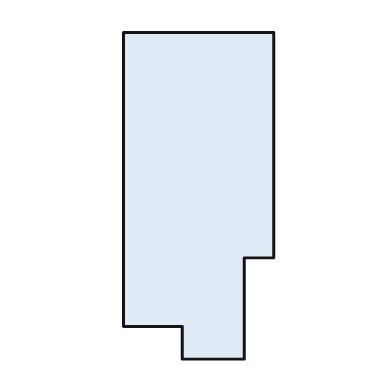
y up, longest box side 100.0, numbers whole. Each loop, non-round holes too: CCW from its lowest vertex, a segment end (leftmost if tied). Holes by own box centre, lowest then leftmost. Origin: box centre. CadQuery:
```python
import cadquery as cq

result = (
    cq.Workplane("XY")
    .moveTo(-5.0, -50.0)
    .lineTo(14.0, -50.0)
    .lineTo(14.0, -19.0)
    .lineTo(23.0, -19.0)
    .lineTo(23.0, 50.0)
    .lineTo(-23.0, 50.0)
    .lineTo(-23.0, -40.0)
    .lineTo(-5.0, -40.0)
    .close()
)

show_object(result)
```